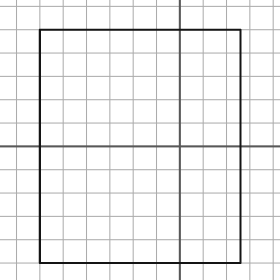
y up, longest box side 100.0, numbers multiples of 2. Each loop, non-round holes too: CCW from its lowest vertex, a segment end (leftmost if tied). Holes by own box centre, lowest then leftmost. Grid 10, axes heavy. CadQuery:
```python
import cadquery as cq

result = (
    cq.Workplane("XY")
    .moveTo(-60.0, -50.0)
    .lineTo(26.0, -50.0)
    .lineTo(26.0, 50.0)
    .lineTo(-60.0, 50.0)
    .close()
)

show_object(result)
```